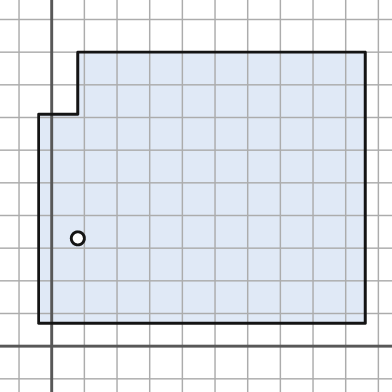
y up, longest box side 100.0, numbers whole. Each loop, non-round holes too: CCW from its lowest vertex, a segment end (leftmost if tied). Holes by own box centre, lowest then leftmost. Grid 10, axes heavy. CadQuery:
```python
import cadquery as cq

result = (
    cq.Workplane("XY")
    .moveTo(-4.0, 7.0)
    .lineTo(96.0, 7.0)
    .lineTo(96.0, 90.0)
    .lineTo(8.0, 90.0)
    .lineTo(8.0, 71.0)
    .lineTo(-4.0, 71.0)
    .close()
    .moveTo(8.0, 33.0)
    .circle(2.0)
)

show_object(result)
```